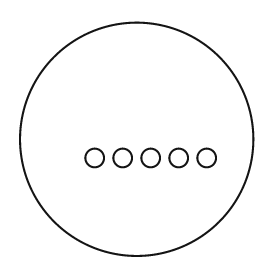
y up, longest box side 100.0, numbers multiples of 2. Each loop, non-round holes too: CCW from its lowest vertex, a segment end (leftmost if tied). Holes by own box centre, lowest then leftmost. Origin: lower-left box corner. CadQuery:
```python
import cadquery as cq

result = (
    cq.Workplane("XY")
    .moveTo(50.0, 50.0)
    .circle(50.0)
    .moveTo(32.0, 42.0)
    .circle(4.0)
    .moveTo(44.0, 42.0)
    .circle(4.0)
    .moveTo(56.0, 42.0)
    .circle(4.0)
    .moveTo(68.0, 42.0)
    .circle(4.0)
    .moveTo(80.0, 42.0)
    .circle(4.0)
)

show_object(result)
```